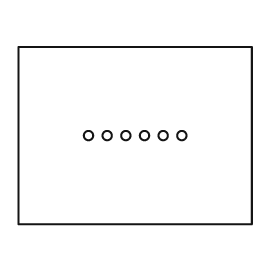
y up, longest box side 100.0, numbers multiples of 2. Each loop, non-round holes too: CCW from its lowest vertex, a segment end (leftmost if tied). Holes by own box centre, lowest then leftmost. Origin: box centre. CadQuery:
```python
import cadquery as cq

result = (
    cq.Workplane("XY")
    .moveTo(-50.0, -38.0)
    .lineTo(50.0, -38.0)
    .lineTo(50.0, 38.0)
    .lineTo(-50.0, 38.0)
    .close()
    .moveTo(-20.0, 0.0)
    .circle(2.0)
    .moveTo(-12.0, 0.0)
    .circle(2.0)
    .moveTo(-4.0, 0.0)
    .circle(2.0)
    .moveTo(4.0, 0.0)
    .circle(2.0)
    .moveTo(12.0, 0.0)
    .circle(2.0)
    .moveTo(20.0, 0.0)
    .circle(2.0)
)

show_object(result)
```